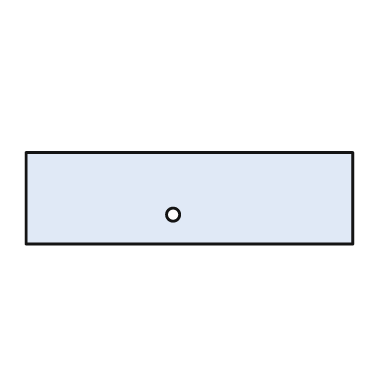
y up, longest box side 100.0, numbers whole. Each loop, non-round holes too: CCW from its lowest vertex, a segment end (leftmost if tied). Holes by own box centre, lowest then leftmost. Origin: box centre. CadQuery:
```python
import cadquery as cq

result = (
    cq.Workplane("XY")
    .moveTo(-50.0, -14.0)
    .lineTo(50.0, -14.0)
    .lineTo(50.0, 14.0)
    .lineTo(-50.0, 14.0)
    .close()
    .moveTo(-5.0, -5.0)
    .circle(2.0)
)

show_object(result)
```